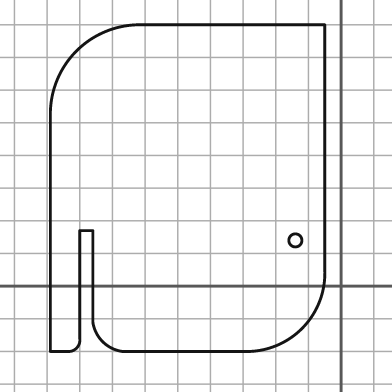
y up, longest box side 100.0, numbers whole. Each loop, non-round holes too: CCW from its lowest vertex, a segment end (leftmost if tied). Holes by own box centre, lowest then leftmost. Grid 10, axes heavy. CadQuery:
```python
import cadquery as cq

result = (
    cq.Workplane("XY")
    .moveTo(-89.0, -20.0)
    .lineTo(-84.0, -20.0)
    .threePointArc((-81.0, -19.0), (-80.0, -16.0))
    .lineTo(-80.0, 17.0)
    .lineTo(-76.0, 17.0)
    .lineTo(-76.0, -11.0)
    .threePointArc((-73.0, -17.0), (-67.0, -20.0))
    .lineTo(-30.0, -20.0)
    .threePointArc((-12.0, -13.0), (-5.0, 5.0))
    .lineTo(-5.0, 80.0)
    .lineTo(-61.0, 80.0)
    .threePointArc((-81.0, 72.0), (-89.0, 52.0))
    .close()
    .moveTo(-14.0, 14.0)
    .circle(2.0)
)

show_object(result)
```